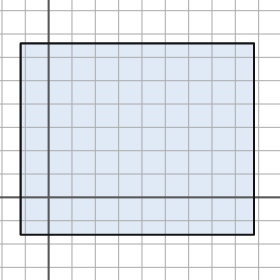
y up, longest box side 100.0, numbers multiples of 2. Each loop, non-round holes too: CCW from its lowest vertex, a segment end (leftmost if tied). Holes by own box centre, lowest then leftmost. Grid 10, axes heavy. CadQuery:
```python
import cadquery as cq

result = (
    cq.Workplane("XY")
    .moveTo(-12.0, -16.0)
    .lineTo(88.0, -16.0)
    .lineTo(88.0, 66.0)
    .lineTo(-12.0, 66.0)
    .close()
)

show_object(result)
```